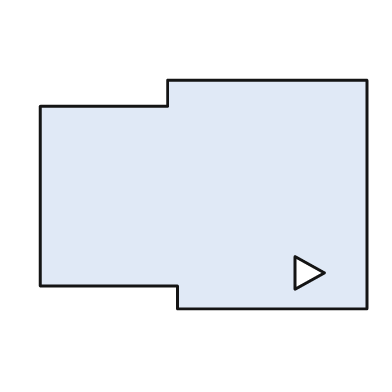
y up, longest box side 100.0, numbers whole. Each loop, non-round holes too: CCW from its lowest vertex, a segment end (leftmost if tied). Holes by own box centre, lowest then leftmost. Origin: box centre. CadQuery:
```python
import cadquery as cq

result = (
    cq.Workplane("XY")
    .moveTo(-8.0, -35.0)
    .lineTo(50.0, -35.0)
    .lineTo(50.0, 35.0)
    .lineTo(-11.0, 35.0)
    .lineTo(-11.0, 27.0)
    .lineTo(-50.0, 27.0)
    .lineTo(-50.0, -28.0)
    .lineTo(-8.0, -28.0)
    .close()
    .moveTo(28.0, -29.0)
    .lineTo(37.0, -24.0)
    .lineTo(28.0, -19.0)
    .close()
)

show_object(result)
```